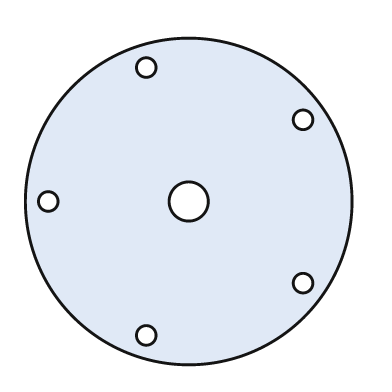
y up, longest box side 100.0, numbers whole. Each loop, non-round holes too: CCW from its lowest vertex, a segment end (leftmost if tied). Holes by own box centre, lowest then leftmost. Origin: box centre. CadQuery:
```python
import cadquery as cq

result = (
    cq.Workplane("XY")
    .moveTo(0.0, 0.0)
    .circle(50.0)
    .moveTo(-13.0, -41.0)
    .circle(3.0)
    .moveTo(35.0, -25.0)
    .circle(3.0)
    .moveTo(-43.0, 0.0)
    .circle(3.0)
    .moveTo(0.0, 0.0)
    .circle(6.0)
    .moveTo(35.0, 25.0)
    .circle(3.0)
    .moveTo(-13.0, 41.0)
    .circle(3.0)
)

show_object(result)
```